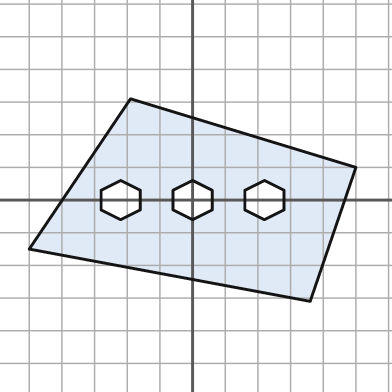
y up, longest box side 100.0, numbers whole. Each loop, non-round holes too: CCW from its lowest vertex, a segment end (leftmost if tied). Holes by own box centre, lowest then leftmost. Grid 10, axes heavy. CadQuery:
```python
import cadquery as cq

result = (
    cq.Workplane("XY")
    .moveTo(36.0, -31.0)
    .lineTo(50.0, 10.0)
    .lineTo(-19.0, 31.0)
    .lineTo(-50.0, -15.0)
    .close()
    .moveTo(-22.0, -6.0)
    .lineTo(-16.0, -3.0)
    .lineTo(-16.0, 3.0)
    .lineTo(-22.0, 6.0)
    .lineTo(-28.0, 3.0)
    .lineTo(-28.0, -3.0)
    .close()
    .moveTo(0.0, -6.0)
    .lineTo(6.0, -3.0)
    .lineTo(6.0, 3.0)
    .lineTo(0.0, 6.0)
    .lineTo(-6.0, 3.0)
    .lineTo(-6.0, -3.0)
    .close()
    .moveTo(22.0, -6.0)
    .lineTo(28.0, -3.0)
    .lineTo(28.0, 3.0)
    .lineTo(22.0, 6.0)
    .lineTo(16.0, 3.0)
    .lineTo(16.0, -3.0)
    .close()
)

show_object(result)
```